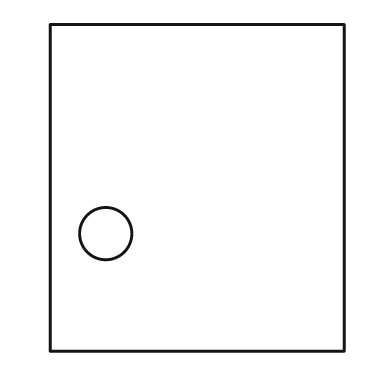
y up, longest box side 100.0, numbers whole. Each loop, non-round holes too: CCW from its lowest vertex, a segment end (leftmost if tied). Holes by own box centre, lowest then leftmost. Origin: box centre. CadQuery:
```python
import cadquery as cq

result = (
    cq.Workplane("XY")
    .moveTo(-45.0, -50.0)
    .lineTo(45.0, -50.0)
    .lineTo(45.0, 50.0)
    .lineTo(-45.0, 50.0)
    .close()
    .moveTo(-28.0, -14.0)
    .circle(8.0)
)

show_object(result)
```